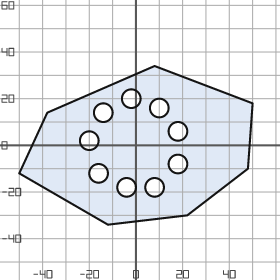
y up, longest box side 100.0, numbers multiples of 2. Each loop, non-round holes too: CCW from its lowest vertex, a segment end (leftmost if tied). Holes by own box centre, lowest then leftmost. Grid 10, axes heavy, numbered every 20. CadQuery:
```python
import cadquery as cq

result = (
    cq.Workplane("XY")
    .moveTo(-12.0, -34.0)
    .lineTo(22.0, -30.0)
    .lineTo(48.0, -10.0)
    .lineTo(50.0, 18.0)
    .lineTo(8.0, 34.0)
    .lineTo(-38.0, 14.0)
    .lineTo(-50.0, -12.0)
    .close()
    .moveTo(-4.0, -18.0)
    .circle(4.0)
    .moveTo(8.0, -18.0)
    .circle(4.0)
    .moveTo(-16.0, -12.0)
    .circle(4.0)
    .moveTo(18.0, -8.0)
    .circle(4.0)
    .moveTo(-20.0, 2.0)
    .circle(4.0)
    .moveTo(18.0, 6.0)
    .circle(4.0)
    .moveTo(-14.0, 14.0)
    .circle(4.0)
    .moveTo(10.0, 16.0)
    .circle(4.0)
    .moveTo(-2.0, 20.0)
    .circle(4.0)
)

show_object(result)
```